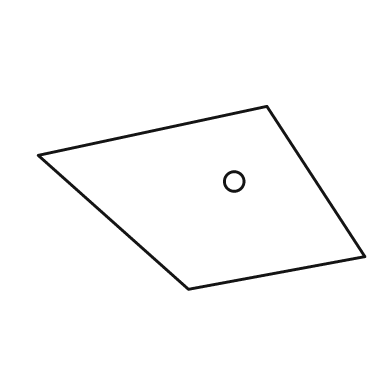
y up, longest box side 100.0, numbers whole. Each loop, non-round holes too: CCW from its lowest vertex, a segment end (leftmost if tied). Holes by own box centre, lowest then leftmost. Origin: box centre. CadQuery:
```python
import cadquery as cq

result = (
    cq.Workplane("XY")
    .moveTo(-4.0, -28.0)
    .lineTo(50.0, -18.0)
    .lineTo(20.0, 28.0)
    .lineTo(-50.0, 13.0)
    .close()
    .moveTo(10.0, 5.0)
    .circle(3.0)
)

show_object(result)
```